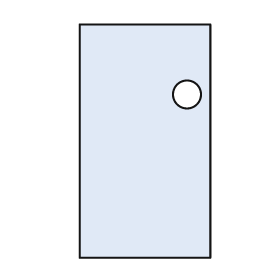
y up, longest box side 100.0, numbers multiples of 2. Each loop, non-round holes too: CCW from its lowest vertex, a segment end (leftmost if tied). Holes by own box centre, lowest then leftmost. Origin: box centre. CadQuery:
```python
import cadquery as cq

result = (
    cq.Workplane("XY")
    .moveTo(-28.0, -50.0)
    .lineTo(28.0, -50.0)
    .lineTo(28.0, 50.0)
    .lineTo(-28.0, 50.0)
    .close()
    .moveTo(18.0, 20.0)
    .circle(6.0)
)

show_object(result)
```